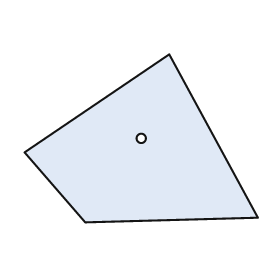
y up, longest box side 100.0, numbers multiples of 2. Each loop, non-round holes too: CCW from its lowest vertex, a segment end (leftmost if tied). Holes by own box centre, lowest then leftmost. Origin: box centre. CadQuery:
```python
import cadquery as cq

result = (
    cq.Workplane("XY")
    .moveTo(-24.0, -36.0)
    .lineTo(50.0, -34.0)
    .lineTo(12.0, 36.0)
    .lineTo(-50.0, -6.0)
    .close()
    .moveTo(0.0, 0.0)
    .circle(2.0)
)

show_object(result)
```